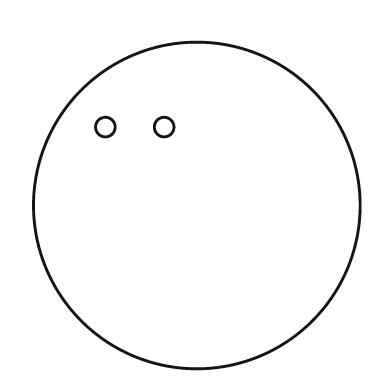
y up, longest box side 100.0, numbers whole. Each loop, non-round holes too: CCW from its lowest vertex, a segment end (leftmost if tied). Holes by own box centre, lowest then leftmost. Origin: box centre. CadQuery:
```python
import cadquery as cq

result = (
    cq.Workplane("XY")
    .moveTo(0.0, 0.0)
    .circle(50.0)
    .moveTo(-28.0, 24.0)
    .circle(3.0)
    .moveTo(-10.0, 24.0)
    .circle(3.0)
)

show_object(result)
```